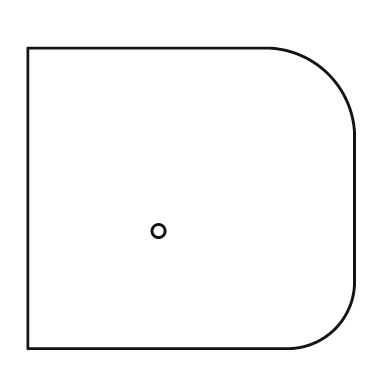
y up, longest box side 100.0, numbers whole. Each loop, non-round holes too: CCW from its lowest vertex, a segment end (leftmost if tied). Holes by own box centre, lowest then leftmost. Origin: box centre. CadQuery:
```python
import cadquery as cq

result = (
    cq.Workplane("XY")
    .moveTo(-50.0, -46.0)
    .lineTo(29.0, -46.0)
    .threePointArc((44.0, -40.0), (50.0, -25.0))
    .lineTo(50.0, 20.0)
    .threePointArc((42.0, 38.0), (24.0, 46.0))
    .lineTo(-50.0, 46.0)
    .close()
    .moveTo(-10.0, -10.0)
    .circle(2.0)
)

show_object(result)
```